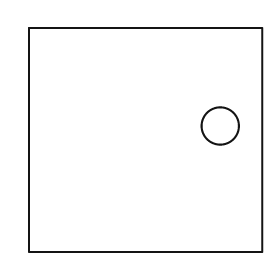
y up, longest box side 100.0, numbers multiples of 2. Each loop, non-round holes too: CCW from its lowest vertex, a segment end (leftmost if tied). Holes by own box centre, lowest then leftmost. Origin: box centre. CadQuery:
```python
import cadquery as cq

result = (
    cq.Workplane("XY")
    .moveTo(-50.0, -48.0)
    .lineTo(50.0, -48.0)
    .lineTo(50.0, 48.0)
    .lineTo(-50.0, 48.0)
    .close()
    .moveTo(32.0, 6.0)
    .circle(8.0)
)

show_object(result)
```